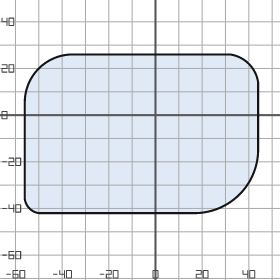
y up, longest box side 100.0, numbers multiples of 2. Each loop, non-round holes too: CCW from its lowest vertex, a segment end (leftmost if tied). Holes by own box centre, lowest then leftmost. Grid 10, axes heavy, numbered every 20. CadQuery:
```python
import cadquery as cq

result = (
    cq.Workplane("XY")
    .moveTo(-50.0, -42.0)
    .lineTo(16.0, -42.0)
    .threePointArc((36.0, -34.0), (44.0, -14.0))
    .lineTo(44.0, 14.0)
    .threePointArc((40.0, 22.0), (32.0, 26.0))
    .lineTo(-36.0, 26.0)
    .threePointArc((-50.0, 20.0), (-56.0, 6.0))
    .lineTo(-56.0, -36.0)
    .threePointArc((-54.0, -40.0), (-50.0, -42.0))
    .close()
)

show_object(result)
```